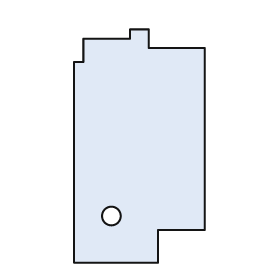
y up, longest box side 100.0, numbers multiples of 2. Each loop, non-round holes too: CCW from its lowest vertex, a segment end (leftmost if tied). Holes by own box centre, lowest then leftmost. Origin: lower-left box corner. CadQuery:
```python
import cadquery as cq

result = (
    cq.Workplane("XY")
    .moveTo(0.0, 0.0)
    .lineTo(36.0, 0.0)
    .lineTo(36.0, 14.0)
    .lineTo(56.0, 14.0)
    .lineTo(56.0, 92.0)
    .lineTo(32.0, 92.0)
    .lineTo(32.0, 100.0)
    .lineTo(24.0, 100.0)
    .lineTo(24.0, 96.0)
    .lineTo(4.0, 96.0)
    .lineTo(4.0, 86.0)
    .lineTo(0.0, 86.0)
    .close()
    .moveTo(16.0, 20.0)
    .circle(4.0)
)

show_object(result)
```